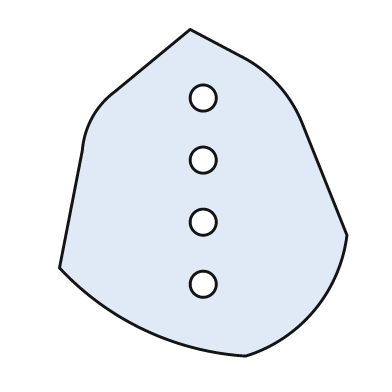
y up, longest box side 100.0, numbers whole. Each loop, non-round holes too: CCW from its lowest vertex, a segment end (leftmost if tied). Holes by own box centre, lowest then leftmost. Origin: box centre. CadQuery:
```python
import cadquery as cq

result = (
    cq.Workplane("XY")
    .moveTo(13.0, -50.0)
    .threePointArc((34.0, -36.0), (44.0, -13.0))
    .lineTo(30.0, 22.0)
    .threePointArc((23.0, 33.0), (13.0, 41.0))
    .lineTo(-4.0, 50.0)
    .lineTo(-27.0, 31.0)
    .threePointArc((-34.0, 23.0), (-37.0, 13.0))
    .lineTo(-44.0, -23.0)
    .threePointArc((-18.0, -42.0), (13.0, -50.0))
    .close()
    .moveTo(0.0, -28.0)
    .circle(4.0)
    .moveTo(0.0, -9.0)
    .circle(4.0)
    .moveTo(0.0, 10.0)
    .circle(4.0)
    .moveTo(0.0, 29.0)
    .circle(4.0)
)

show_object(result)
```